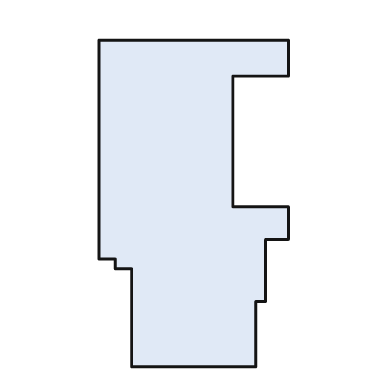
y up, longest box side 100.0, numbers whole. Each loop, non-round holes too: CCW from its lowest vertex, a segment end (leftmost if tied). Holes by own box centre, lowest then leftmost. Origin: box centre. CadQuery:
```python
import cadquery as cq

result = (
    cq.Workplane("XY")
    .moveTo(-19.0, -50.0)
    .lineTo(19.0, -50.0)
    .lineTo(19.0, -30.0)
    .lineTo(22.0, -30.0)
    .lineTo(22.0, -11.0)
    .lineTo(29.0, -11.0)
    .lineTo(29.0, -1.0)
    .lineTo(12.0, -1.0)
    .lineTo(12.0, 39.0)
    .lineTo(29.0, 39.0)
    .lineTo(29.0, 50.0)
    .lineTo(-29.0, 50.0)
    .lineTo(-29.0, -17.0)
    .lineTo(-24.0, -17.0)
    .lineTo(-24.0, -20.0)
    .lineTo(-19.0, -20.0)
    .close()
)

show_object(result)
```